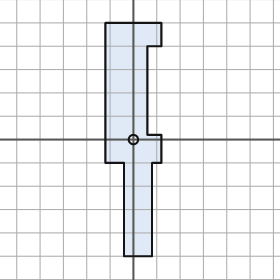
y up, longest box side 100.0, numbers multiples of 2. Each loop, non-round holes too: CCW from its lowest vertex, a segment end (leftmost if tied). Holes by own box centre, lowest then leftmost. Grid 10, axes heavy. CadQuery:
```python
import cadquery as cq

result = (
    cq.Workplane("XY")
    .moveTo(-4.0, -50.0)
    .lineTo(8.0, -50.0)
    .lineTo(8.0, -10.0)
    .lineTo(12.0, -10.0)
    .lineTo(12.0, 2.0)
    .lineTo(6.0, 2.0)
    .lineTo(6.0, 40.0)
    .lineTo(12.0, 40.0)
    .lineTo(12.0, 50.0)
    .lineTo(-12.0, 50.0)
    .lineTo(-12.0, -10.0)
    .lineTo(-4.0, -10.0)
    .close()
    .moveTo(0.0, 0.0)
    .circle(2.0)
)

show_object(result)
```